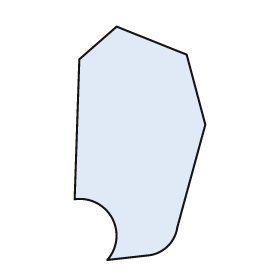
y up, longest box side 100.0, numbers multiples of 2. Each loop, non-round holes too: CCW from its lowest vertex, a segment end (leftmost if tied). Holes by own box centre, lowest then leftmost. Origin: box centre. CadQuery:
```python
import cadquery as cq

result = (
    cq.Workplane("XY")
    .moveTo(-14.0, -50.0)
    .lineTo(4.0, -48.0)
    .threePointArc((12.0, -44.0), (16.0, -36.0))
    .lineTo(28.0, 8.0)
    .lineTo(20.0, 38.0)
    .lineTo(-10.0, 50.0)
    .lineTo(-26.0, 36.0)
    .lineTo(-28.0, -24.0)
    .threePointArc((-12.0, -32.0), (-14.0, -50.0))
    .close()
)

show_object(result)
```